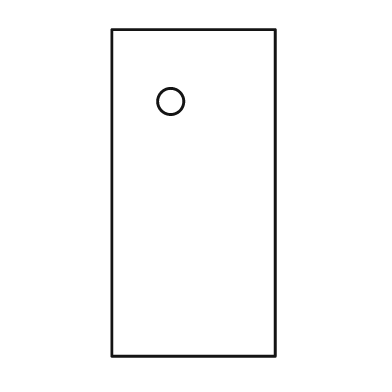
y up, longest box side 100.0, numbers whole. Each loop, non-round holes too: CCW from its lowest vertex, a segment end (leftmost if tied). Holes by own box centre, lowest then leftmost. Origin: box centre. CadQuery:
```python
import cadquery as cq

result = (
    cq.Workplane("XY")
    .moveTo(-25.0, -50.0)
    .lineTo(25.0, -50.0)
    .lineTo(25.0, 50.0)
    .lineTo(-25.0, 50.0)
    .close()
    .moveTo(-7.0, 28.0)
    .circle(4.0)
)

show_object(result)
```